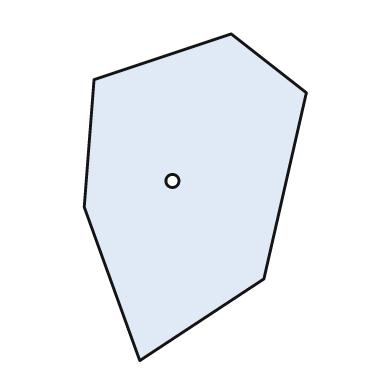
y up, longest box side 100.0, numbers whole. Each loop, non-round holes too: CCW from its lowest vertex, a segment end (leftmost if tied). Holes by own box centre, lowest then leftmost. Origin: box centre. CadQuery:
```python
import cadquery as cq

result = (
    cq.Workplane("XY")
    .moveTo(-17.0, -50.0)
    .lineTo(21.0, -25.0)
    .lineTo(34.0, 32.0)
    .lineTo(11.0, 50.0)
    .lineTo(-31.0, 36.0)
    .lineTo(-34.0, -3.0)
    .close()
    .moveTo(-7.0, 5.0)
    .circle(2.0)
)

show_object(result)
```